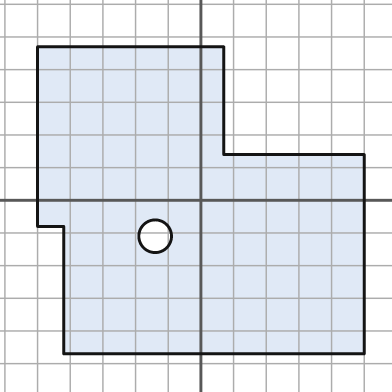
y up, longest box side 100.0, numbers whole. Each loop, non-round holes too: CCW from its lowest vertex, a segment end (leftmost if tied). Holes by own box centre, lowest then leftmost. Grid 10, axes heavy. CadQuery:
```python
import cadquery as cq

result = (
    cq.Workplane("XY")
    .moveTo(-42.0, -47.0)
    .lineTo(50.0, -47.0)
    .lineTo(50.0, 14.0)
    .lineTo(7.0, 14.0)
    .lineTo(7.0, 47.0)
    .lineTo(-50.0, 47.0)
    .lineTo(-50.0, -8.0)
    .lineTo(-42.0, -8.0)
    .close()
    .moveTo(-14.0, -11.0)
    .circle(5.0)
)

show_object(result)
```